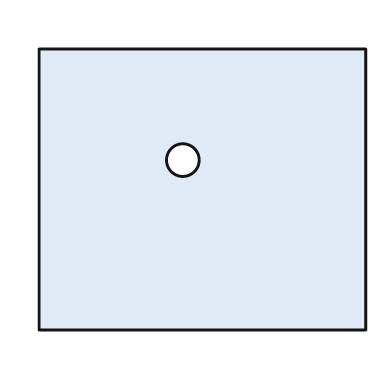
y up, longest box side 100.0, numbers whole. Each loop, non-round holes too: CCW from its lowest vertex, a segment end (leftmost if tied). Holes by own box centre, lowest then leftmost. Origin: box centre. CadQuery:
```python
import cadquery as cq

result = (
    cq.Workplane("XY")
    .moveTo(-50.0, -43.0)
    .lineTo(50.0, -43.0)
    .lineTo(50.0, 43.0)
    .lineTo(-50.0, 43.0)
    .close()
    .moveTo(-6.0, 9.0)
    .circle(5.0)
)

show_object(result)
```